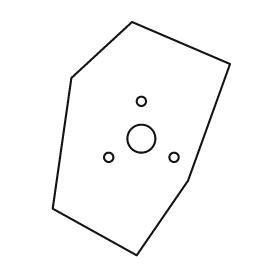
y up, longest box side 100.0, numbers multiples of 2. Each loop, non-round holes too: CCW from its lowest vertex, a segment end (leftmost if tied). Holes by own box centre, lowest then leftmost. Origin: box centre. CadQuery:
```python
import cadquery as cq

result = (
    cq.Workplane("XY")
    .moveTo(-2.0, -50.0)
    .lineTo(20.0, -18.0)
    .lineTo(38.0, 32.0)
    .lineTo(-4.0, 50.0)
    .lineTo(-30.0, 26.0)
    .lineTo(-38.0, -30.0)
    .close()
    .moveTo(-14.0, -8.0)
    .circle(2.0)
    .moveTo(14.0, -8.0)
    .circle(2.0)
    .moveTo(0.0, 0.0)
    .circle(6.0)
    .moveTo(0.0, 16.0)
    .circle(2.0)
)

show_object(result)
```